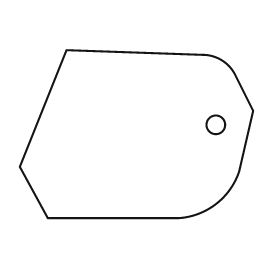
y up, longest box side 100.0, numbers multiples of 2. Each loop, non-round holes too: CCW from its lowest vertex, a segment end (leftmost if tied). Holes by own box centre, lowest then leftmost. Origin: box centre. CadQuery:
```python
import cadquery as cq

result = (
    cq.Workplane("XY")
    .moveTo(-38.0, -36.0)
    .lineTo(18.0, -36.0)
    .threePointArc((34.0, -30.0), (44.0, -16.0))
    .lineTo(50.0, 10.0)
    .lineTo(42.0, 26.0)
    .threePointArc((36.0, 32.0), (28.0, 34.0))
    .lineTo(-30.0, 36.0)
    .lineTo(-50.0, -14.0)
    .close()
    .moveTo(34.0, 4.0)
    .circle(4.0)
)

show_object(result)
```